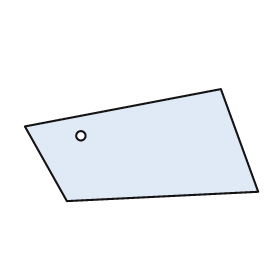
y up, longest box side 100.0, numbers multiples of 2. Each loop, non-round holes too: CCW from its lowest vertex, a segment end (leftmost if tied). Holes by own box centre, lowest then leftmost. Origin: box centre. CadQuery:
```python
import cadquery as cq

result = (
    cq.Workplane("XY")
    .moveTo(-32.0, -24.0)
    .lineTo(50.0, -20.0)
    .lineTo(34.0, 24.0)
    .lineTo(-50.0, 8.0)
    .close()
    .moveTo(-26.0, 4.0)
    .circle(2.0)
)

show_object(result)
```